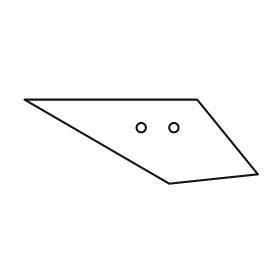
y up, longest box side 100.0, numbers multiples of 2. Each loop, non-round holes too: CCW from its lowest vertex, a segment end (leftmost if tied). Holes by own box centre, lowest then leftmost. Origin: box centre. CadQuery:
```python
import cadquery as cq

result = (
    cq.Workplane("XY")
    .moveTo(12.0, -18.0)
    .lineTo(50.0, -14.0)
    .lineTo(24.0, 18.0)
    .lineTo(-50.0, 18.0)
    .close()
    .moveTo(0.0, 6.0)
    .circle(2.0)
    .moveTo(14.0, 6.0)
    .circle(2.0)
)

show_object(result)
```